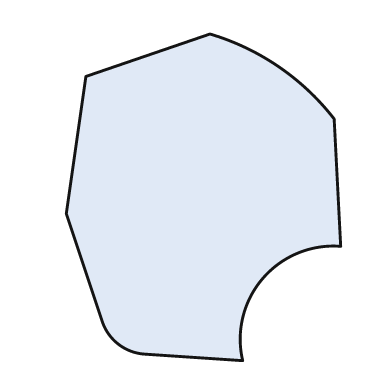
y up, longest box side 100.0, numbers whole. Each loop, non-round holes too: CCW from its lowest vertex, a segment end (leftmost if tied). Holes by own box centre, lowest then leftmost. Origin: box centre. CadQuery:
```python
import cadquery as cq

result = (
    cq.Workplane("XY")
    .moveTo(12.0, -50.0)
    .threePointArc((18.0, -25.0), (42.0, -15.0))
    .lineTo(40.0, 24.0)
    .threePointArc((23.0, 40.0), (2.0, 50.0))
    .lineTo(-36.0, 37.0)
    .lineTo(-42.0, -5.0)
    .lineTo(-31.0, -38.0)
    .threePointArc((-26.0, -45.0), (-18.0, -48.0))
    .close()
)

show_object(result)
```